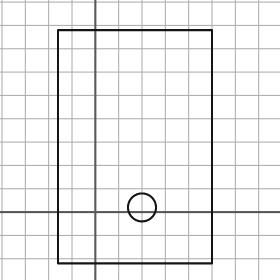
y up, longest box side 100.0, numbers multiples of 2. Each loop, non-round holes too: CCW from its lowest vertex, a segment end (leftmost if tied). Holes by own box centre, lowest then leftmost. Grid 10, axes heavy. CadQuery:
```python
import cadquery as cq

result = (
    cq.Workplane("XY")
    .moveTo(-16.0, -22.0)
    .lineTo(50.0, -22.0)
    .lineTo(50.0, 78.0)
    .lineTo(-16.0, 78.0)
    .close()
    .moveTo(20.0, 2.0)
    .circle(6.0)
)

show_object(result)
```